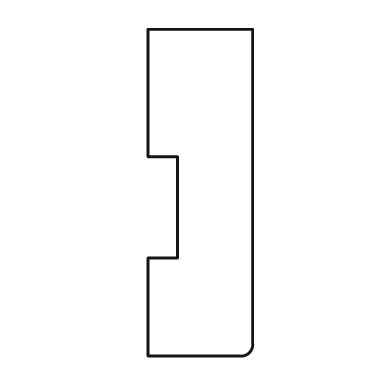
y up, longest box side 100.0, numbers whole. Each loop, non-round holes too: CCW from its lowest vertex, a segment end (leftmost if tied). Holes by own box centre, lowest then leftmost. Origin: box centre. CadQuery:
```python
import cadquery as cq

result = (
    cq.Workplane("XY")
    .moveTo(-16.0, -50.0)
    .lineTo(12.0, -50.0)
    .threePointArc((15.0, -49.0), (16.0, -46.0))
    .lineTo(16.0, 50.0)
    .lineTo(-16.0, 50.0)
    .lineTo(-16.0, 11.0)
    .lineTo(-7.0, 11.0)
    .lineTo(-7.0, -20.0)
    .lineTo(-16.0, -20.0)
    .close()
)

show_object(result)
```